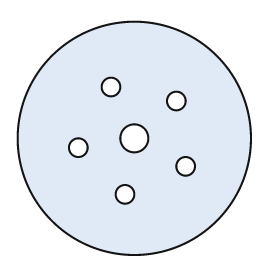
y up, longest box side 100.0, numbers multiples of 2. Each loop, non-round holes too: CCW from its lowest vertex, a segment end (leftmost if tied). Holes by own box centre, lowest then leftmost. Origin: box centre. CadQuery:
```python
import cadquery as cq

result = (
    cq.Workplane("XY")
    .moveTo(0.0, 0.0)
    .circle(50.0)
    .moveTo(-4.0, -24.0)
    .circle(4.0)
    .moveTo(22.0, -12.0)
    .circle(4.0)
    .moveTo(-24.0, -4.0)
    .circle(4.0)
    .moveTo(0.0, 0.0)
    .circle(6.0)
    .moveTo(18.0, 16.0)
    .circle(4.0)
    .moveTo(-10.0, 22.0)
    .circle(4.0)
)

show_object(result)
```